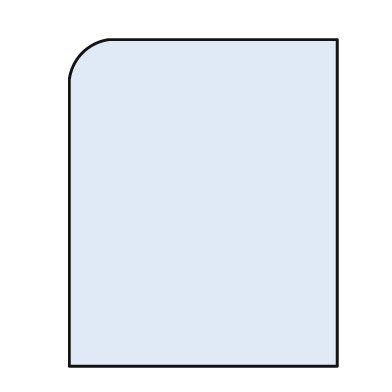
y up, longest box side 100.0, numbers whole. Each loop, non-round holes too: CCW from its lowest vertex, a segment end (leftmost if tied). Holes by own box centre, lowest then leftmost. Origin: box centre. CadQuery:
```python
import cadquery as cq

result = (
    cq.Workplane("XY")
    .moveTo(-41.0, -50.0)
    .lineTo(41.0, -50.0)
    .lineTo(41.0, 50.0)
    .lineTo(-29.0, 50.0)
    .threePointArc((-37.0, 46.0), (-41.0, 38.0))
    .close()
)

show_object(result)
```